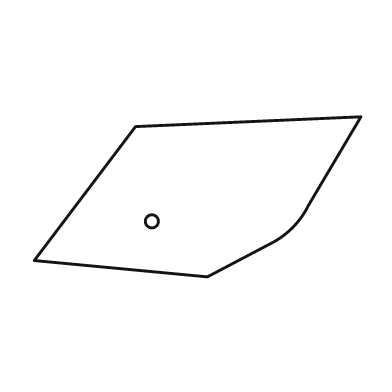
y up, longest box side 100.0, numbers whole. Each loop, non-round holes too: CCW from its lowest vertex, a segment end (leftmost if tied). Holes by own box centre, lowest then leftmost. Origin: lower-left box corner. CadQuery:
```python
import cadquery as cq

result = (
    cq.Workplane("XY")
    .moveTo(53.0, 0.0)
    .lineTo(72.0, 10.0)
    .threePointArc((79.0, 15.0), (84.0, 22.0))
    .lineTo(100.0, 49.0)
    .lineTo(31.0, 46.0)
    .lineTo(0.0, 5.0)
    .close()
    .moveTo(36.0, 17.0)
    .circle(2.0)
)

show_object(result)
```